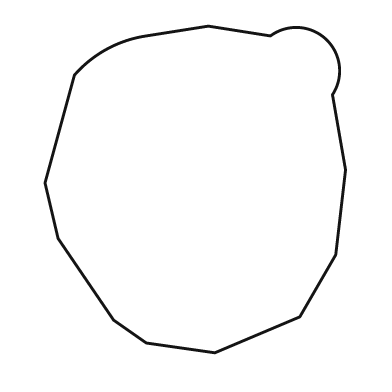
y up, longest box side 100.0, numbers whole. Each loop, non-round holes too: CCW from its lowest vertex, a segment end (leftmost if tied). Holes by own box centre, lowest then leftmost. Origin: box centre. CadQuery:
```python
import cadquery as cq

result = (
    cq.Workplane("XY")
    .moveTo(6.0, -50.0)
    .lineTo(32.0, -39.0)
    .lineTo(43.0, -20.0)
    .lineTo(46.0, 6.0)
    .lineTo(42.0, 29.0)
    .threePointArc((40.0, 46.0), (23.0, 47.0))
    .lineTo(4.0, 50.0)
    .lineTo(-15.0, 47.0)
    .threePointArc((-27.0, 43.0), (-37.0, 35.0))
    .lineTo(-46.0, 2.0)
    .lineTo(-42.0, -15.0)
    .lineTo(-25.0, -40.0)
    .lineTo(-15.0, -47.0)
    .close()
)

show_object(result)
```